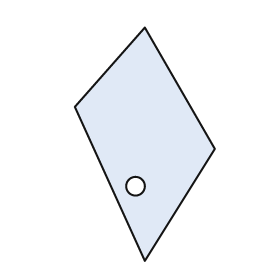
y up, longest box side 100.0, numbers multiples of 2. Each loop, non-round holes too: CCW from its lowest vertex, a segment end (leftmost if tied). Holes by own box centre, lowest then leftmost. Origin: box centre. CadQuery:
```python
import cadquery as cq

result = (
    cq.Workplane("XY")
    .moveTo(0.0, -50.0)
    .lineTo(30.0, -2.0)
    .lineTo(0.0, 50.0)
    .lineTo(-30.0, 16.0)
    .close()
    .moveTo(-4.0, -18.0)
    .circle(4.0)
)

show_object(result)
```